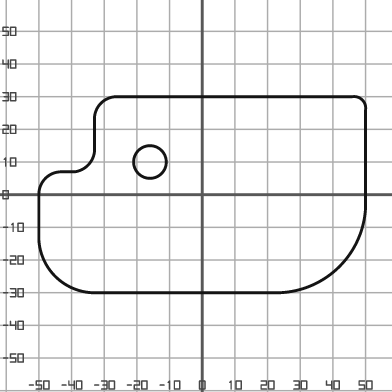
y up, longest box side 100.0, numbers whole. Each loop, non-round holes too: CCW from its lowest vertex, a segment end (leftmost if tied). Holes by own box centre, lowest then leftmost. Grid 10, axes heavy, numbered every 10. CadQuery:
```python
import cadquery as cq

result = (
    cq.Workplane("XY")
    .moveTo(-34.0, -30.0)
    .lineTo(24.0, -30.0)
    .threePointArc((42.0, -22.0), (50.0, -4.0))
    .lineTo(50.0, 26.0)
    .threePointArc((49.0, 29.0), (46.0, 30.0))
    .lineTo(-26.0, 30.0)
    .threePointArc((-31.0, 28.0), (-33.0, 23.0))
    .lineTo(-33.0, 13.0)
    .threePointArc((-35.0, 9.0), (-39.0, 7.0))
    .lineTo(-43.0, 7.0)
    .threePointArc((-48.0, 5.0), (-50.0, 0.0))
    .lineTo(-50.0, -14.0)
    .threePointArc((-45.0, -25.0), (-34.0, -30.0))
    .close()
    .moveTo(-16.0, 10.0)
    .circle(5.0)
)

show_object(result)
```